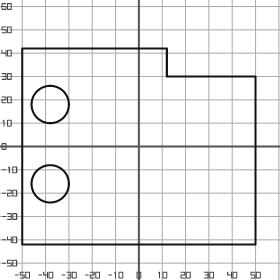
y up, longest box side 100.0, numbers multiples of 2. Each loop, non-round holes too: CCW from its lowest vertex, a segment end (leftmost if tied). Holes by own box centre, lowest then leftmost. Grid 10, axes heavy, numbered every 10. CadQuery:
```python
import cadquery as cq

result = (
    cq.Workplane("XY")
    .moveTo(-50.0, -42.0)
    .lineTo(50.0, -42.0)
    .lineTo(50.0, 30.0)
    .lineTo(12.0, 30.0)
    .lineTo(12.0, 42.0)
    .lineTo(-50.0, 42.0)
    .close()
    .moveTo(-38.0, -16.0)
    .circle(8.0)
    .moveTo(-38.0, 18.0)
    .circle(8.0)
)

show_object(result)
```